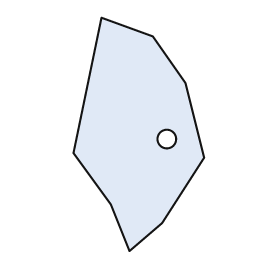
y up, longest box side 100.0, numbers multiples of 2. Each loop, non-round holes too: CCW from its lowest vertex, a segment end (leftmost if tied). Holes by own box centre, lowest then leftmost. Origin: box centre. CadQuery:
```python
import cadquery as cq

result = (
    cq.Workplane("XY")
    .moveTo(-4.0, -50.0)
    .lineTo(10.0, -38.0)
    .lineTo(28.0, -10.0)
    .lineTo(20.0, 22.0)
    .lineTo(6.0, 42.0)
    .lineTo(-16.0, 50.0)
    .lineTo(-28.0, -8.0)
    .lineTo(-12.0, -30.0)
    .close()
    .moveTo(12.0, -2.0)
    .circle(4.0)
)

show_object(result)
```